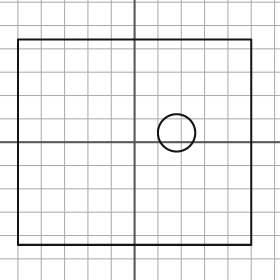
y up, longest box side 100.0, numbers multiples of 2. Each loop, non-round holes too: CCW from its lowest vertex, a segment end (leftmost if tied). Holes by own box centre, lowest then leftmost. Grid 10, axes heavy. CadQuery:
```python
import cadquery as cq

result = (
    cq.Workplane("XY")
    .moveTo(-50.0, -44.0)
    .lineTo(50.0, -44.0)
    .lineTo(50.0, 44.0)
    .lineTo(-50.0, 44.0)
    .close()
    .moveTo(18.0, 4.0)
    .circle(8.0)
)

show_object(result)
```